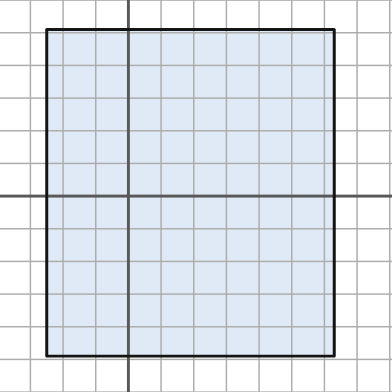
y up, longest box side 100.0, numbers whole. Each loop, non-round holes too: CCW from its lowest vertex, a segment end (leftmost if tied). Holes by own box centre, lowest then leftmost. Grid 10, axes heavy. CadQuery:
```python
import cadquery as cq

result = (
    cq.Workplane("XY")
    .moveTo(-25.0, -49.0)
    .lineTo(63.0, -49.0)
    .lineTo(63.0, 51.0)
    .lineTo(-25.0, 51.0)
    .close()
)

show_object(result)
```